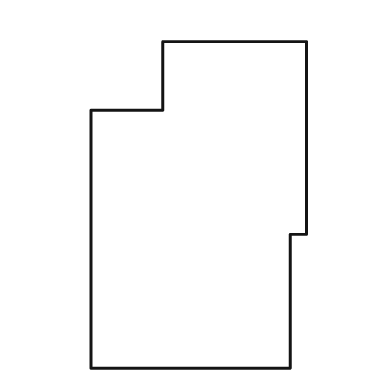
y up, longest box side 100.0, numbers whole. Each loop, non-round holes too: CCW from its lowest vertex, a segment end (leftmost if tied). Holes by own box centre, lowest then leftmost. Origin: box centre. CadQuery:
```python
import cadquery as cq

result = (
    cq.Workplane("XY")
    .moveTo(-33.0, -50.0)
    .lineTo(28.0, -50.0)
    .lineTo(28.0, -9.0)
    .lineTo(33.0, -9.0)
    .lineTo(33.0, 50.0)
    .lineTo(-11.0, 50.0)
    .lineTo(-11.0, 29.0)
    .lineTo(-33.0, 29.0)
    .close()
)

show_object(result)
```